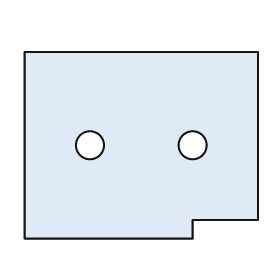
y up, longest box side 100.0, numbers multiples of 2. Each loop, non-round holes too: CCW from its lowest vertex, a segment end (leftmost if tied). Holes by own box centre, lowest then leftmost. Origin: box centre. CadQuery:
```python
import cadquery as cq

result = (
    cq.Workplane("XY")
    .moveTo(-50.0, -40.0)
    .lineTo(22.0, -40.0)
    .lineTo(22.0, -32.0)
    .lineTo(50.0, -32.0)
    .lineTo(50.0, 40.0)
    .lineTo(-50.0, 40.0)
    .close()
    .moveTo(-22.0, 0.0)
    .circle(6.0)
    .moveTo(22.0, 0.0)
    .circle(6.0)
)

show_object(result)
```